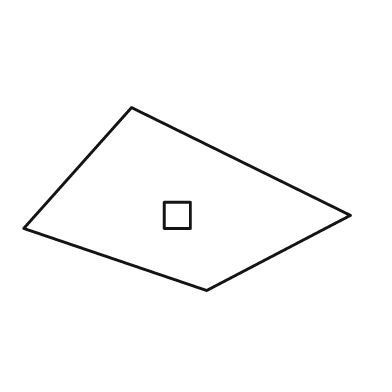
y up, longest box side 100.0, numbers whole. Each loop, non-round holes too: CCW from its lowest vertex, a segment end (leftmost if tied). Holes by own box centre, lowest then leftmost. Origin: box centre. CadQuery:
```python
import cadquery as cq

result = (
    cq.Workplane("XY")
    .moveTo(6.0, -28.0)
    .lineTo(50.0, -5.0)
    .lineTo(-17.0, 28.0)
    .lineTo(-50.0, -9.0)
    .close()
    .moveTo(-7.0, -9.0)
    .lineTo(1.0, -9.0)
    .lineTo(1.0, -1.0)
    .lineTo(-7.0, -1.0)
    .close()
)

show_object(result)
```